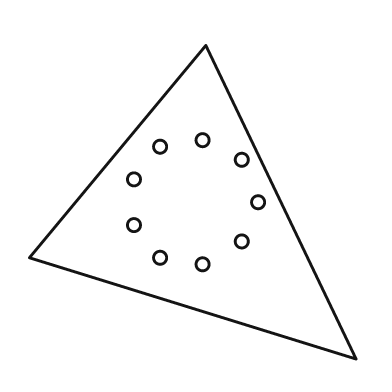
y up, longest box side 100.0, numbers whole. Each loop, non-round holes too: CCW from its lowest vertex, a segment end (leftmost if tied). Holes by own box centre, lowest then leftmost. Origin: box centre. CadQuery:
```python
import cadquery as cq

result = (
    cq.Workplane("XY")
    .moveTo(50.0, -48.0)
    .lineTo(4.0, 48.0)
    .lineTo(-50.0, -17.0)
    .close()
    .moveTo(3.0, -19.0)
    .circle(2.0)
    .moveTo(-10.0, -17.0)
    .circle(2.0)
    .moveTo(15.0, -12.0)
    .circle(2.0)
    .moveTo(-18.0, -7.0)
    .circle(2.0)
    .moveTo(20.0, 0.0)
    .circle(2.0)
    .moveTo(-18.0, 7.0)
    .circle(2.0)
    .moveTo(15.0, 13.0)
    .circle(2.0)
    .moveTo(-10.0, 17.0)
    .circle(2.0)
    .moveTo(3.0, 19.0)
    .circle(2.0)
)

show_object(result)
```